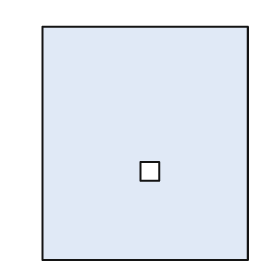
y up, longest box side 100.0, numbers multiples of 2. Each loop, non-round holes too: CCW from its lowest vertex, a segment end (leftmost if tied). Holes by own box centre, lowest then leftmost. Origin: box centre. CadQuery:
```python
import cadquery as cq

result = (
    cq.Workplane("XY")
    .moveTo(-44.0, -50.0)
    .lineTo(44.0, -50.0)
    .lineTo(44.0, 50.0)
    .lineTo(-44.0, 50.0)
    .close()
    .moveTo(-2.0, -16.0)
    .lineTo(6.0, -16.0)
    .lineTo(6.0, -8.0)
    .lineTo(-2.0, -8.0)
    .close()
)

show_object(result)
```